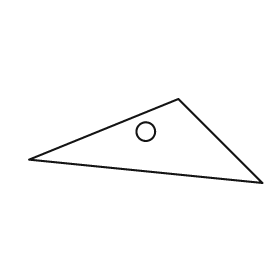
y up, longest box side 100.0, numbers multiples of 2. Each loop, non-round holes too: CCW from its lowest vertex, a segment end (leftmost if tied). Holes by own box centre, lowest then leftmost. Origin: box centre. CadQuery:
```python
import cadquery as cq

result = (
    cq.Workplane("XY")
    .moveTo(50.0, -18.0)
    .lineTo(14.0, 18.0)
    .lineTo(-50.0, -8.0)
    .close()
    .moveTo(0.0, 4.0)
    .circle(4.0)
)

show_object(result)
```